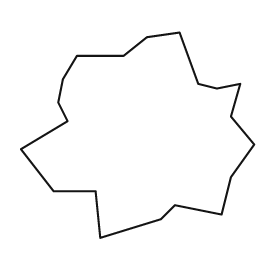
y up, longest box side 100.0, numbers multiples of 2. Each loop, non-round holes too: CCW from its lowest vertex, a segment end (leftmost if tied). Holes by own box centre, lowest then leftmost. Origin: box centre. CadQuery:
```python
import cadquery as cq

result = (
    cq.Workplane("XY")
    .moveTo(-16.0, -44.0)
    .lineTo(10.0, -36.0)
    .lineTo(16.0, -30.0)
    .lineTo(36.0, -34.0)
    .lineTo(40.0, -18.0)
    .lineTo(50.0, -4.0)
    .lineTo(40.0, 8.0)
    .lineTo(44.0, 22.0)
    .lineTo(34.0, 20.0)
    .lineTo(26.0, 22.0)
    .lineTo(18.0, 44.0)
    .lineTo(4.0, 42.0)
    .lineTo(-6.0, 34.0)
    .lineTo(-26.0, 34.0)
    .lineTo(-32.0, 24.0)
    .lineTo(-34.0, 14.0)
    .lineTo(-30.0, 6.0)
    .lineTo(-50.0, -6.0)
    .lineTo(-36.0, -24.0)
    .lineTo(-18.0, -24.0)
    .close()
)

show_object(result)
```